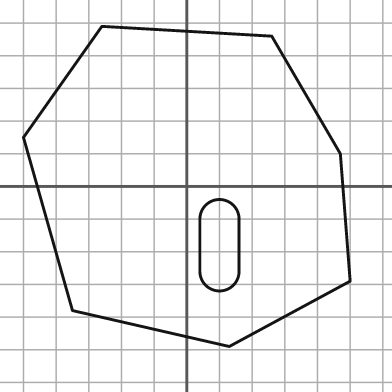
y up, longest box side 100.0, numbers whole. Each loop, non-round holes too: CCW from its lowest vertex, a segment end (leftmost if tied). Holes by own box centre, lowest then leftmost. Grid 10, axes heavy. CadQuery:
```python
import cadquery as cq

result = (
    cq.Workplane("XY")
    .moveTo(13.0, -49.0)
    .lineTo(50.0, -29.0)
    .lineTo(47.0, 10.0)
    .lineTo(26.0, 46.0)
    .lineTo(-26.0, 49.0)
    .lineTo(-50.0, 15.0)
    .lineTo(-35.0, -38.0)
    .close()
    .moveTo(4.0, -26.0)
    .threePointArc((10.0, -32.0), (16.0, -26.0))
    .lineTo(16.0, -10.0)
    .threePointArc((10.0, -4.0), (4.0, -10.0))
    .close()
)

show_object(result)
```